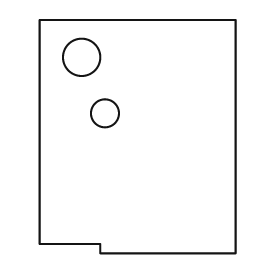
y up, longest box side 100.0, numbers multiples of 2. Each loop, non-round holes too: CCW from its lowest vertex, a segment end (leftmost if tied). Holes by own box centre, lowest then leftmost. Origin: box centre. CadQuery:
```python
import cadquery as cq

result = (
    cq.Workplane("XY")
    .moveTo(-16.0, -50.0)
    .lineTo(42.0, -50.0)
    .lineTo(42.0, 50.0)
    .lineTo(-42.0, 50.0)
    .lineTo(-42.0, -46.0)
    .lineTo(-16.0, -46.0)
    .close()
    .moveTo(-14.0, 10.0)
    .circle(6.0)
    .moveTo(-24.0, 34.0)
    .circle(8.0)
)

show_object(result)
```